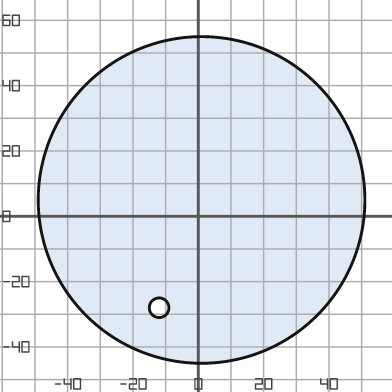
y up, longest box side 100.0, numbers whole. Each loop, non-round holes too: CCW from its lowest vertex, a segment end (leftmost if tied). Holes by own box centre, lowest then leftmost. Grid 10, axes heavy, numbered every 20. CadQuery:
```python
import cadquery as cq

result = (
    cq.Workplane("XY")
    .moveTo(1.0, 5.0)
    .circle(50.0)
    .moveTo(-12.0, -28.0)
    .circle(3.0)
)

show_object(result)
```